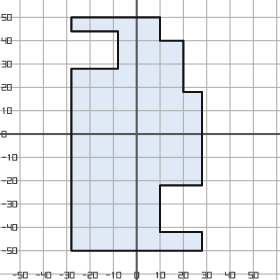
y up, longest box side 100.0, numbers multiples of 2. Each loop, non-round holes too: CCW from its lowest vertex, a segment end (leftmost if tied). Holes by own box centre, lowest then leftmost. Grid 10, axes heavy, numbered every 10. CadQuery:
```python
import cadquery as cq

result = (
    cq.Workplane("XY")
    .moveTo(-28.0, -50.0)
    .lineTo(28.0, -50.0)
    .lineTo(28.0, -42.0)
    .lineTo(10.0, -42.0)
    .lineTo(10.0, -22.0)
    .lineTo(28.0, -22.0)
    .lineTo(28.0, 18.0)
    .lineTo(20.0, 18.0)
    .lineTo(20.0, 40.0)
    .lineTo(10.0, 40.0)
    .lineTo(10.0, 50.0)
    .lineTo(-28.0, 50.0)
    .lineTo(-28.0, 44.0)
    .lineTo(-8.0, 44.0)
    .lineTo(-8.0, 28.0)
    .lineTo(-28.0, 28.0)
    .close()
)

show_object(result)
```